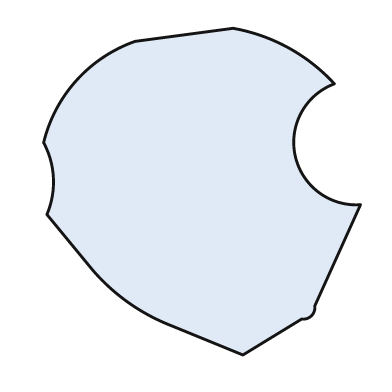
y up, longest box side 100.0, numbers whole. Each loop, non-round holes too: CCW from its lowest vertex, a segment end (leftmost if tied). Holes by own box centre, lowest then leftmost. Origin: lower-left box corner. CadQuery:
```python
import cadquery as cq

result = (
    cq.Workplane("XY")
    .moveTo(61.0, 0.0)
    .lineTo(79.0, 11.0)
    .threePointArc((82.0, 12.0), (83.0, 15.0))
    .lineTo(97.0, 46.0)
    .threePointArc((77.0, 61.0), (89.0, 83.0))
    .threePointArc((75.0, 94.0), (58.0, 100.0))
    .lineTo(28.0, 96.0)
    .threePointArc((10.0, 84.0), (0.0, 65.0))
    .threePointArc((3.0, 54.0), (1.0, 43.0))
    .lineTo(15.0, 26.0)
    .threePointArc((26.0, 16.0), (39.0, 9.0))
    .close()
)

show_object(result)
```